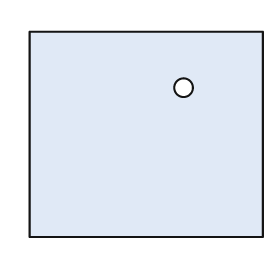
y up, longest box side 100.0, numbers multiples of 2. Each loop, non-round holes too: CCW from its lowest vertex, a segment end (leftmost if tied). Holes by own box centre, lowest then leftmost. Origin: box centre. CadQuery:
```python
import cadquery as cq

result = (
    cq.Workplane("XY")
    .moveTo(-50.0, -44.0)
    .lineTo(50.0, -44.0)
    .lineTo(50.0, 44.0)
    .lineTo(-50.0, 44.0)
    .close()
    .moveTo(16.0, 20.0)
    .circle(4.0)
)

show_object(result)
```